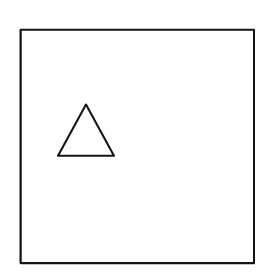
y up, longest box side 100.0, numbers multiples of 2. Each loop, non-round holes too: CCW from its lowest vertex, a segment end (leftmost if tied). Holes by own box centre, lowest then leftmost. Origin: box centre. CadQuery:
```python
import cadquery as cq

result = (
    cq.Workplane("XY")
    .moveTo(-50.0, -50.0)
    .lineTo(50.0, -50.0)
    .lineTo(50.0, 50.0)
    .lineTo(-50.0, 50.0)
    .close()
    .moveTo(-34.0, -4.0)
    .lineTo(-10.0, -4.0)
    .lineTo(-22.0, 18.0)
    .close()
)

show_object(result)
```